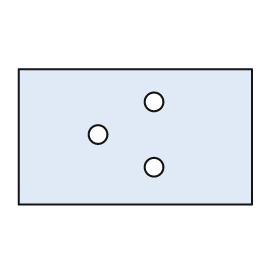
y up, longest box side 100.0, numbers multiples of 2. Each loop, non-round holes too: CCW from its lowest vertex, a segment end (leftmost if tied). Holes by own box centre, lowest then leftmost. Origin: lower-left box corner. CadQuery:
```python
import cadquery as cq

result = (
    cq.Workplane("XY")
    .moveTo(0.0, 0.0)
    .lineTo(100.0, 0.0)
    .lineTo(100.0, 58.0)
    .lineTo(0.0, 58.0)
    .close()
    .moveTo(58.0, 16.0)
    .circle(4.0)
    .moveTo(34.0, 30.0)
    .circle(4.0)
    .moveTo(58.0, 44.0)
    .circle(4.0)
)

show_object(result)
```